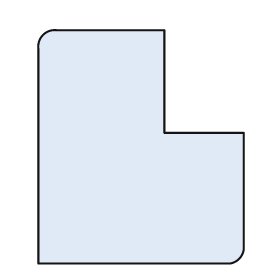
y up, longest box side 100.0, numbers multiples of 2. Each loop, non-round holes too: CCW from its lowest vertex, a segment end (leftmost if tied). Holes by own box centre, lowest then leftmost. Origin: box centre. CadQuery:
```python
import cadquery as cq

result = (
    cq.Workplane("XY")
    .moveTo(-44.0, -50.0)
    .lineTo(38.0, -50.0)
    .threePointArc((42.0, -48.0), (44.0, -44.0))
    .lineTo(44.0, 6.0)
    .lineTo(10.0, 6.0)
    .lineTo(10.0, 50.0)
    .lineTo(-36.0, 50.0)
    .threePointArc((-42.0, 48.0), (-44.0, 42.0))
    .close()
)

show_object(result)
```